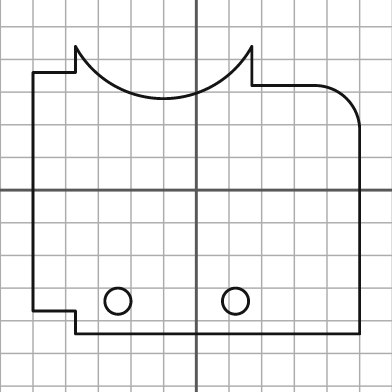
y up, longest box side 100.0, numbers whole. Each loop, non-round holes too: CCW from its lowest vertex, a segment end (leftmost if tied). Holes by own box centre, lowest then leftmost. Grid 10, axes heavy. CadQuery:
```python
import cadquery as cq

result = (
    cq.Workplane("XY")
    .moveTo(-37.0, -44.0)
    .lineTo(50.0, -44.0)
    .lineTo(50.0, 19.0)
    .threePointArc((46.0, 28.0), (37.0, 32.0))
    .lineTo(17.0, 32.0)
    .lineTo(17.0, 44.0)
    .threePointArc((-10.0, 28.0), (-37.0, 44.0))
    .lineTo(-37.0, 36.0)
    .lineTo(-50.0, 36.0)
    .lineTo(-50.0, -37.0)
    .lineTo(-37.0, -37.0)
    .close()
    .moveTo(-24.0, -34.0)
    .circle(4.0)
    .moveTo(12.0, -34.0)
    .circle(4.0)
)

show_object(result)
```